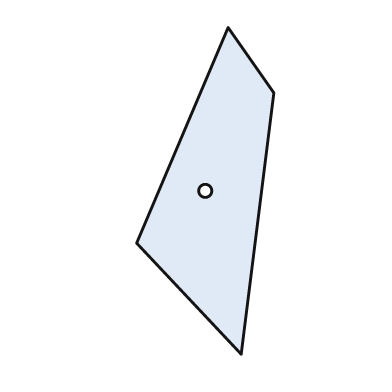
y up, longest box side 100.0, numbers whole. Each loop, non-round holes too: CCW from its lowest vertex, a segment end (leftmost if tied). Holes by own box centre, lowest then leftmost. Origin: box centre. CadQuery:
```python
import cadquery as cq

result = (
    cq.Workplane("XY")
    .moveTo(11.0, -50.0)
    .lineTo(21.0, 30.0)
    .lineTo(7.0, 50.0)
    .lineTo(-21.0, -16.0)
    .close()
    .moveTo(0.0, 0.0)
    .circle(2.0)
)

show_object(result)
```